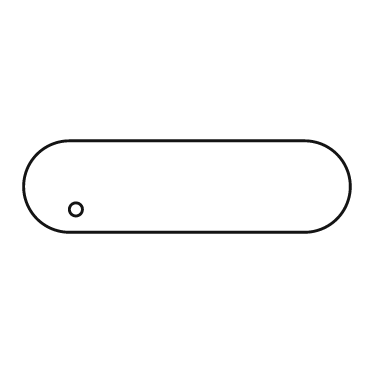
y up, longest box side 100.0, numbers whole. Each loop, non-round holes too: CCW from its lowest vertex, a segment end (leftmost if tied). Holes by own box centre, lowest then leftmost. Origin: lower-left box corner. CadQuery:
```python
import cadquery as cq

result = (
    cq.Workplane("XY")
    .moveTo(14.0, 0.0)
    .lineTo(86.0, 0.0)
    .threePointArc((100.0, 14.0), (86.0, 28.0))
    .lineTo(14.0, 28.0)
    .threePointArc((0.0, 14.0), (14.0, 0.0))
    .close()
    .moveTo(16.0, 7.0)
    .circle(2.0)
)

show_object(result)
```